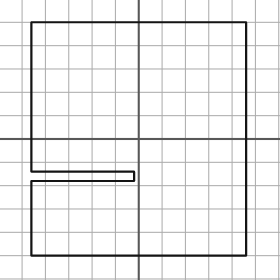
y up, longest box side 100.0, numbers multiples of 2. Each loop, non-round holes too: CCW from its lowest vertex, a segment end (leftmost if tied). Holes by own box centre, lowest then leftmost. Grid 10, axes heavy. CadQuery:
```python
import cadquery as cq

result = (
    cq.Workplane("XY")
    .moveTo(-46.0, -50.0)
    .lineTo(46.0, -50.0)
    .lineTo(46.0, 50.0)
    .lineTo(-46.0, 50.0)
    .lineTo(-46.0, -14.0)
    .lineTo(-2.0, -14.0)
    .lineTo(-2.0, -18.0)
    .lineTo(-46.0, -18.0)
    .close()
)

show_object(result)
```